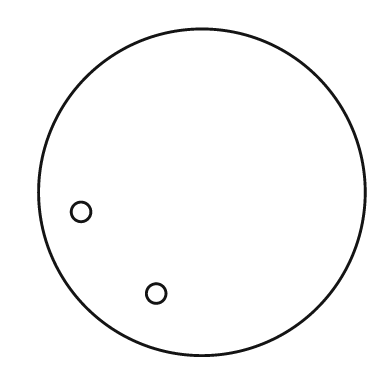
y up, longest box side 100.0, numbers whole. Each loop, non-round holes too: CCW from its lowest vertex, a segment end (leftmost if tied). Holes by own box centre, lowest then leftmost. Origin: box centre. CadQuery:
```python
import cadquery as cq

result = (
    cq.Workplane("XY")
    .moveTo(0.0, 0.0)
    .circle(50.0)
    .moveTo(-14.0, -31.0)
    .circle(3.0)
    .moveTo(-37.0, -6.0)
    .circle(3.0)
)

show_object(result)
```